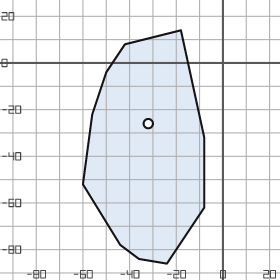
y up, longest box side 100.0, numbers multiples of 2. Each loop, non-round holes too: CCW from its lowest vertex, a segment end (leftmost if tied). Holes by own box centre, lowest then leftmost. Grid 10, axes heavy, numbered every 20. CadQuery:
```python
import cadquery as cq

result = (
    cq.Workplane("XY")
    .moveTo(-24.0, -86.0)
    .lineTo(-8.0, -62.0)
    .lineTo(-8.0, -32.0)
    .lineTo(-18.0, 14.0)
    .lineTo(-42.0, 8.0)
    .lineTo(-50.0, -4.0)
    .lineTo(-56.0, -22.0)
    .lineTo(-60.0, -52.0)
    .lineTo(-44.0, -78.0)
    .lineTo(-36.0, -84.0)
    .close()
    .moveTo(-32.0, -26.0)
    .circle(2.0)
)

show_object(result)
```